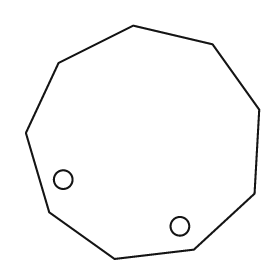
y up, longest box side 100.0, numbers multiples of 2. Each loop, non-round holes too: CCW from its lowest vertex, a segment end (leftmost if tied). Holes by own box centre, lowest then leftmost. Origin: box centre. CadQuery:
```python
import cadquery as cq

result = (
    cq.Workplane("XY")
    .moveTo(-12.0, -50.0)
    .lineTo(22.0, -46.0)
    .lineTo(48.0, -22.0)
    .lineTo(50.0, 14.0)
    .lineTo(30.0, 42.0)
    .lineTo(-4.0, 50.0)
    .lineTo(-36.0, 34.0)
    .lineTo(-50.0, 4.0)
    .lineTo(-40.0, -30.0)
    .close()
    .moveTo(16.0, -36.0)
    .circle(4.0)
    .moveTo(-34.0, -16.0)
    .circle(4.0)
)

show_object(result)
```